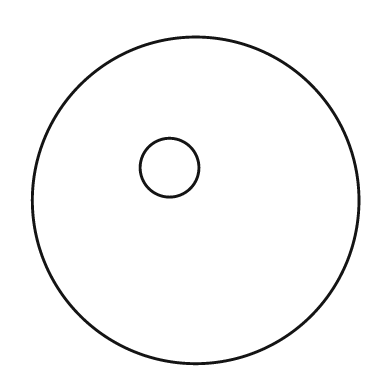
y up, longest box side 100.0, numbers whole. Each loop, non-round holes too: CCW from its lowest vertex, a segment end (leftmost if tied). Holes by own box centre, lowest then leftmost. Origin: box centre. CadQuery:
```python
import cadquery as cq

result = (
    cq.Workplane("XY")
    .moveTo(0.0, 0.0)
    .circle(50.0)
    .moveTo(-8.0, 10.0)
    .circle(9.0)
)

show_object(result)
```